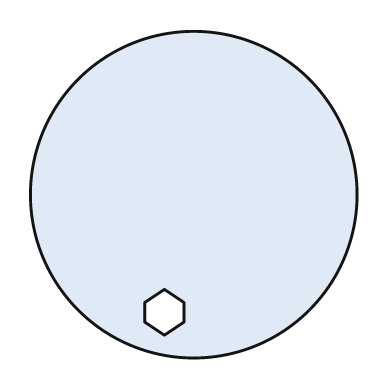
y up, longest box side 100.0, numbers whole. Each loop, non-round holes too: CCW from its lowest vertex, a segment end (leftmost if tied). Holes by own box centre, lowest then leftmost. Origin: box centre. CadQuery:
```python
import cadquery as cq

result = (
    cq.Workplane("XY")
    .moveTo(0.0, 0.0)
    .circle(50.0)
    .moveTo(-9.0, -43.0)
    .lineTo(-3.0, -39.0)
    .lineTo(-3.0, -33.0)
    .lineTo(-9.0, -29.0)
    .lineTo(-15.0, -33.0)
    .lineTo(-15.0, -39.0)
    .close()
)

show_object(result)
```